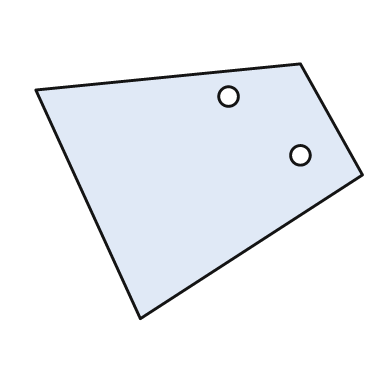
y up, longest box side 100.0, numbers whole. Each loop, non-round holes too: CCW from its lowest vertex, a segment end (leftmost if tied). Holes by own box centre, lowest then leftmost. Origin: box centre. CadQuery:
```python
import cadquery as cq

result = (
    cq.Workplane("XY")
    .moveTo(-18.0, -39.0)
    .lineTo(50.0, 5.0)
    .lineTo(31.0, 39.0)
    .lineTo(-50.0, 31.0)
    .close()
    .moveTo(31.0, 11.0)
    .circle(3.0)
    .moveTo(9.0, 29.0)
    .circle(3.0)
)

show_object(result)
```